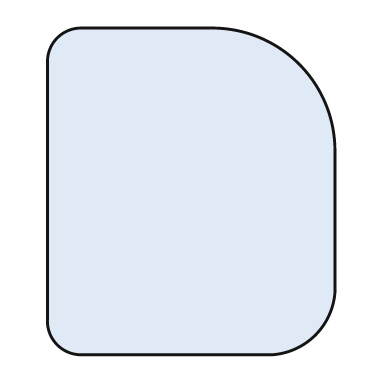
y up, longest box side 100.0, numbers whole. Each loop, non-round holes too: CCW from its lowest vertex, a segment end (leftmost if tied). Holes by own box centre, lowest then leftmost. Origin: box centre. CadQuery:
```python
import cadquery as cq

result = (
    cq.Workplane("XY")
    .moveTo(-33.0, -50.0)
    .lineTo(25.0, -50.0)
    .threePointArc((38.0, -44.0), (44.0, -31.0))
    .lineTo(44.0, 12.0)
    .threePointArc((33.0, 39.0), (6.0, 50.0))
    .lineTo(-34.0, 50.0)
    .threePointArc((-41.0, 47.0), (-44.0, 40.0))
    .lineTo(-44.0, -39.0)
    .threePointArc((-41.0, -47.0), (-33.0, -50.0))
    .close()
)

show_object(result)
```